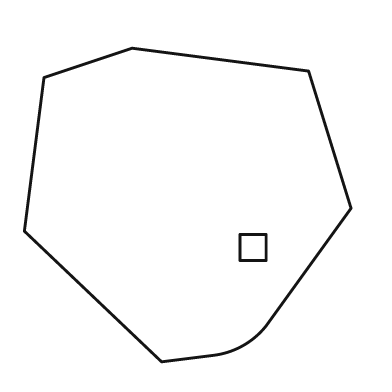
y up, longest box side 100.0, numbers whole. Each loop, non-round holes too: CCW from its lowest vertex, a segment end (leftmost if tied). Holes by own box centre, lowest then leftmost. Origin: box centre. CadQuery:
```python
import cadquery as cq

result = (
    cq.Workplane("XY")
    .moveTo(-8.0, -48.0)
    .lineTo(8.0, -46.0)
    .threePointArc((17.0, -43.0), (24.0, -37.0))
    .lineTo(50.0, -1.0)
    .lineTo(37.0, 41.0)
    .lineTo(-17.0, 48.0)
    .lineTo(-44.0, 39.0)
    .lineTo(-50.0, -8.0)
    .close()
    .moveTo(16.0, -17.0)
    .lineTo(24.0, -17.0)
    .lineTo(24.0, -9.0)
    .lineTo(16.0, -9.0)
    .close()
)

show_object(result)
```